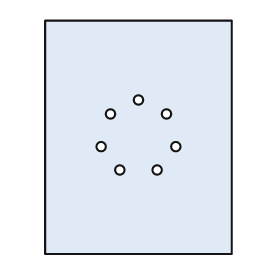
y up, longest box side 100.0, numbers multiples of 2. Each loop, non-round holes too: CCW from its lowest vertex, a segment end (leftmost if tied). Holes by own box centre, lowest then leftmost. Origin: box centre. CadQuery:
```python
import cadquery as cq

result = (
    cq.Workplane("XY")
    .moveTo(-40.0, -50.0)
    .lineTo(40.0, -50.0)
    .lineTo(40.0, 50.0)
    .lineTo(-40.0, 50.0)
    .close()
    .moveTo(-8.0, -14.0)
    .circle(2.0)
    .moveTo(8.0, -14.0)
    .circle(2.0)
    .moveTo(-16.0, -4.0)
    .circle(2.0)
    .moveTo(16.0, -4.0)
    .circle(2.0)
    .moveTo(-12.0, 10.0)
    .circle(2.0)
    .moveTo(12.0, 10.0)
    .circle(2.0)
    .moveTo(0.0, 16.0)
    .circle(2.0)
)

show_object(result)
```